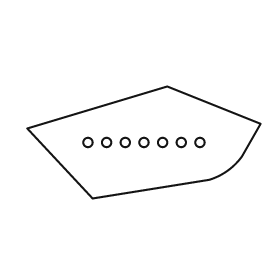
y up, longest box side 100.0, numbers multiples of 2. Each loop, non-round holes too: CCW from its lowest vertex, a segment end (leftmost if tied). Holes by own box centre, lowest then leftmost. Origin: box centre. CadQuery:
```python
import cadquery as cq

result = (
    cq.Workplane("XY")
    .moveTo(-22.0, -24.0)
    .lineTo(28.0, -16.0)
    .threePointArc((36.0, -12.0), (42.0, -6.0))
    .lineTo(50.0, 8.0)
    .lineTo(10.0, 24.0)
    .lineTo(-50.0, 6.0)
    .close()
    .moveTo(-24.0, 0.0)
    .circle(2.0)
    .moveTo(-16.0, 0.0)
    .circle(2.0)
    .moveTo(-8.0, 0.0)
    .circle(2.0)
    .moveTo(0.0, 0.0)
    .circle(2.0)
    .moveTo(8.0, 0.0)
    .circle(2.0)
    .moveTo(16.0, 0.0)
    .circle(2.0)
    .moveTo(24.0, 0.0)
    .circle(2.0)
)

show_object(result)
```